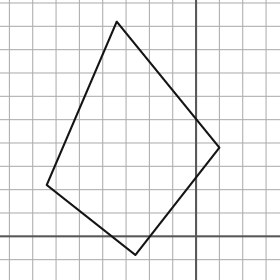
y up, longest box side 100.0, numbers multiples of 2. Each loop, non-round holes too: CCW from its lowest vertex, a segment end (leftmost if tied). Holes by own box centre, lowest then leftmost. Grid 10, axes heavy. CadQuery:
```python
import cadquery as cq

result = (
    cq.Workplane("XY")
    .moveTo(-26.0, -8.0)
    .lineTo(10.0, 38.0)
    .lineTo(-34.0, 92.0)
    .lineTo(-64.0, 22.0)
    .close()
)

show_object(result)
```